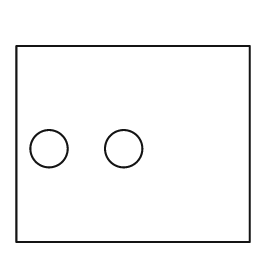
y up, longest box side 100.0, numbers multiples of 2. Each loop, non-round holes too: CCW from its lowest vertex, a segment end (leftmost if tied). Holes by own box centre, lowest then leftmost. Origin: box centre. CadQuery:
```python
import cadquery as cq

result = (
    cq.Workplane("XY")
    .moveTo(-50.0, -42.0)
    .lineTo(50.0, -42.0)
    .lineTo(50.0, 42.0)
    .lineTo(-50.0, 42.0)
    .close()
    .moveTo(-36.0, -2.0)
    .circle(8.0)
    .moveTo(-4.0, -2.0)
    .circle(8.0)
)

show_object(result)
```